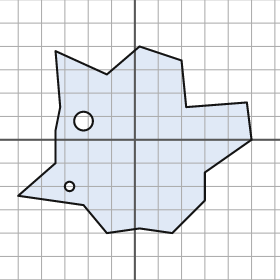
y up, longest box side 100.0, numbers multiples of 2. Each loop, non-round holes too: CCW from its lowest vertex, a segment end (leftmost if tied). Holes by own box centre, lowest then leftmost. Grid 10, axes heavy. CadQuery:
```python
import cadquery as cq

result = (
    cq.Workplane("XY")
    .moveTo(-12.0, -40.0)
    .lineTo(2.0, -38.0)
    .lineTo(16.0, -40.0)
    .lineTo(30.0, -26.0)
    .lineTo(30.0, -14.0)
    .lineTo(50.0, 0.0)
    .lineTo(48.0, 16.0)
    .lineTo(22.0, 14.0)
    .lineTo(20.0, 34.0)
    .lineTo(2.0, 40.0)
    .lineTo(-12.0, 28.0)
    .lineTo(-34.0, 38.0)
    .lineTo(-32.0, 14.0)
    .lineTo(-34.0, 4.0)
    .lineTo(-34.0, -10.0)
    .lineTo(-50.0, -24.0)
    .lineTo(-22.0, -28.0)
    .close()
    .moveTo(-28.0, -20.0)
    .circle(2.0)
    .moveTo(-22.0, 8.0)
    .circle(4.0)
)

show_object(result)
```